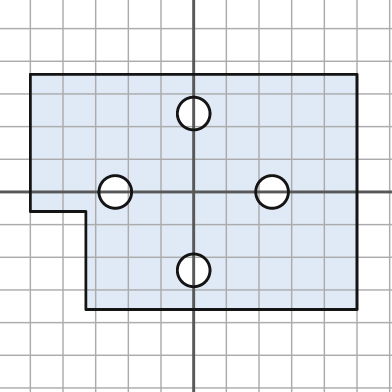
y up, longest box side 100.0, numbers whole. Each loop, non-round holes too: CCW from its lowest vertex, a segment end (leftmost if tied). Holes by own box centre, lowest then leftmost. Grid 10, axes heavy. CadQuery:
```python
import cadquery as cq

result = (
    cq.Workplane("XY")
    .moveTo(-33.0, -36.0)
    .lineTo(50.0, -36.0)
    .lineTo(50.0, 36.0)
    .lineTo(-50.0, 36.0)
    .lineTo(-50.0, -6.0)
    .lineTo(-33.0, -6.0)
    .close()
    .moveTo(0.0, -24.0)
    .circle(5.0)
    .moveTo(-24.0, 0.0)
    .circle(5.0)
    .moveTo(24.0, 0.0)
    .circle(5.0)
    .moveTo(0.0, 24.0)
    .circle(5.0)
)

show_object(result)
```